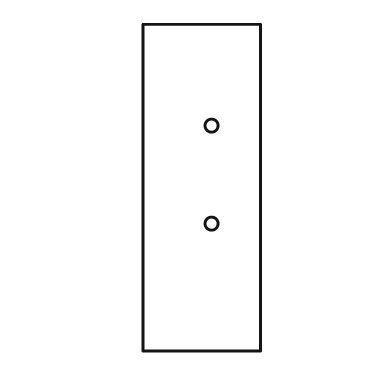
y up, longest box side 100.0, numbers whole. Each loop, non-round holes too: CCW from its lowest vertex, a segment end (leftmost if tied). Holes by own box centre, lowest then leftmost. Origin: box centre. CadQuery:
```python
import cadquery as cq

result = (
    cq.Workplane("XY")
    .moveTo(-18.0, -50.0)
    .lineTo(18.0, -50.0)
    .lineTo(18.0, 50.0)
    .lineTo(-18.0, 50.0)
    .close()
    .moveTo(3.0, -11.0)
    .circle(2.0)
    .moveTo(3.0, 19.0)
    .circle(2.0)
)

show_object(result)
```